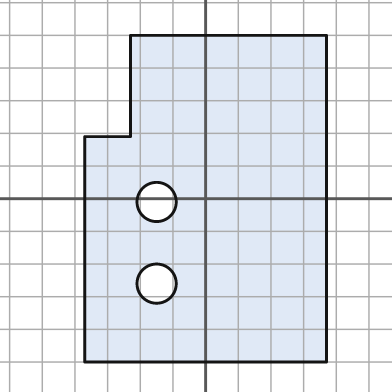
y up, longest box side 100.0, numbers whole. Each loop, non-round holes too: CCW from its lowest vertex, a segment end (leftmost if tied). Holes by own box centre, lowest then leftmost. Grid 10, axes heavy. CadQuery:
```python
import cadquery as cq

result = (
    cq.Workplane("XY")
    .moveTo(-37.0, -50.0)
    .lineTo(37.0, -50.0)
    .lineTo(37.0, 50.0)
    .lineTo(-23.0, 50.0)
    .lineTo(-23.0, 19.0)
    .lineTo(-37.0, 19.0)
    .close()
    .moveTo(-15.0, -26.0)
    .circle(6.0)
    .moveTo(-15.0, -1.0)
    .circle(6.0)
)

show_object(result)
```